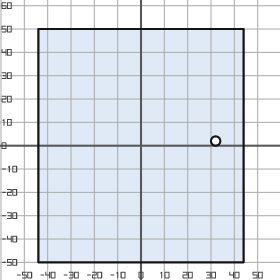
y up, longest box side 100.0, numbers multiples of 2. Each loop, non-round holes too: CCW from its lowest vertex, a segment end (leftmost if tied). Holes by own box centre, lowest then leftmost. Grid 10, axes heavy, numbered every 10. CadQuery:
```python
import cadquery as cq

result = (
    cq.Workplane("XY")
    .moveTo(-44.0, -50.0)
    .lineTo(44.0, -50.0)
    .lineTo(44.0, 50.0)
    .lineTo(-44.0, 50.0)
    .close()
    .moveTo(32.0, 2.0)
    .circle(2.0)
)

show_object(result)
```